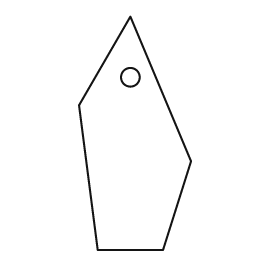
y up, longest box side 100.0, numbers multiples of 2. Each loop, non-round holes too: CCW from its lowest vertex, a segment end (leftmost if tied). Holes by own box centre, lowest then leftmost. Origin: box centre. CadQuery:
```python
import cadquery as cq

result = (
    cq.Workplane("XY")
    .moveTo(-16.0, -50.0)
    .lineTo(12.0, -50.0)
    .lineTo(24.0, -12.0)
    .lineTo(-2.0, 50.0)
    .lineTo(-24.0, 12.0)
    .close()
    .moveTo(-2.0, 24.0)
    .circle(4.0)
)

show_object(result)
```